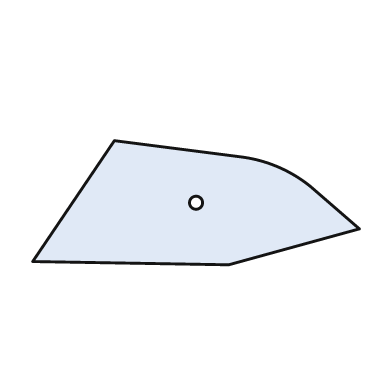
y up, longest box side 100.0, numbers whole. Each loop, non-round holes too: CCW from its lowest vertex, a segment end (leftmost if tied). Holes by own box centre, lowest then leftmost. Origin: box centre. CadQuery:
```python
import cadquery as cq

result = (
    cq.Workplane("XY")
    .moveTo(10.0, -19.0)
    .lineTo(50.0, -8.0)
    .lineTo(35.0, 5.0)
    .threePointArc((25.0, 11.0), (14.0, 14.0))
    .lineTo(-25.0, 19.0)
    .lineTo(-50.0, -18.0)
    .close()
    .moveTo(0.0, 0.0)
    .circle(2.0)
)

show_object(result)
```